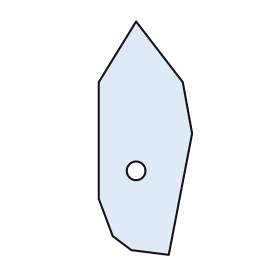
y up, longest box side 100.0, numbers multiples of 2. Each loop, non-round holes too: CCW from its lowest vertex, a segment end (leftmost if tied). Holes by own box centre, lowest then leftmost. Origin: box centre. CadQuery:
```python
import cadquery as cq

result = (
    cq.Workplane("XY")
    .moveTo(10.0, -50.0)
    .lineTo(20.0, 2.0)
    .lineTo(16.0, 24.0)
    .lineTo(-4.0, 50.0)
    .lineTo(-20.0, 24.0)
    .lineTo(-20.0, -26.0)
    .lineTo(-14.0, -42.0)
    .lineTo(-6.0, -48.0)
    .close()
    .moveTo(-4.0, -14.0)
    .circle(4.0)
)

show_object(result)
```